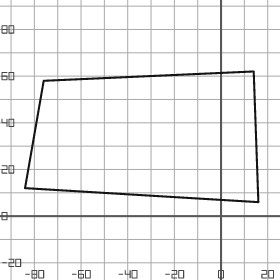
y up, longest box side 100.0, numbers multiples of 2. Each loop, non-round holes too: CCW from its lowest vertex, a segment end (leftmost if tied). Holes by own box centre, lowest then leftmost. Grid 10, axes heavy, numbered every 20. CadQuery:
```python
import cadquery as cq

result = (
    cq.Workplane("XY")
    .moveTo(16.0, 6.0)
    .lineTo(14.0, 62.0)
    .lineTo(-76.0, 58.0)
    .lineTo(-84.0, 12.0)
    .close()
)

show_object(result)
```